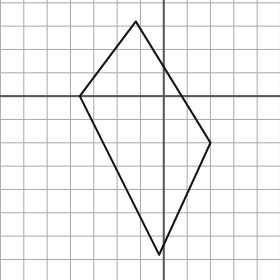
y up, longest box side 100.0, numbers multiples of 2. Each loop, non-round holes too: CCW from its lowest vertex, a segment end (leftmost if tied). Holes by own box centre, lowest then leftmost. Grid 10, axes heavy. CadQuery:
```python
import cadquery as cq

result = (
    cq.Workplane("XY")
    .moveTo(-2.0, -68.0)
    .lineTo(20.0, -20.0)
    .lineTo(-12.0, 32.0)
    .lineTo(-36.0, 0.0)
    .close()
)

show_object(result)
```